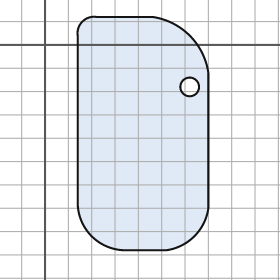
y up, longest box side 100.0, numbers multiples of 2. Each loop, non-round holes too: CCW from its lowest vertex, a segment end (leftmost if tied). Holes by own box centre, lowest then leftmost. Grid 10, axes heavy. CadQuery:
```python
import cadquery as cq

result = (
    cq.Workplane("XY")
    .moveTo(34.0, -88.0)
    .lineTo(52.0, -88.0)
    .threePointArc((64.0, -82.0), (70.0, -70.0))
    .lineTo(70.0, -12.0)
    .threePointArc((62.0, 4.0), (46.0, 12.0))
    .lineTo(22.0, 12.0)
    .threePointArc((16.0, 10.0), (14.0, 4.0))
    .lineTo(14.0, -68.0)
    .threePointArc((20.0, -82.0), (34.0, -88.0))
    .close()
    .moveTo(62.0, -18.0)
    .circle(4.0)
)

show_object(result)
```